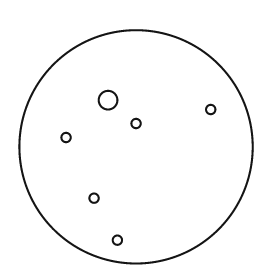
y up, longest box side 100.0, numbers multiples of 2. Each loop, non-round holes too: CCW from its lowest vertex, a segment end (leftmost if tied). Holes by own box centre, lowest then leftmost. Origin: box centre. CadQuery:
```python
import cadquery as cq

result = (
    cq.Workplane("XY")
    .moveTo(0.0, 0.0)
    .circle(50.0)
    .moveTo(-8.0, -40.0)
    .circle(2.0)
    .moveTo(-18.0, -22.0)
    .circle(2.0)
    .moveTo(-30.0, 4.0)
    .circle(2.0)
    .moveTo(0.0, 10.0)
    .circle(2.0)
    .moveTo(32.0, 16.0)
    .circle(2.0)
    .moveTo(-12.0, 20.0)
    .circle(4.0)
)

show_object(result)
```